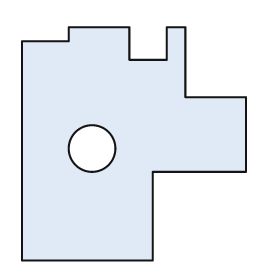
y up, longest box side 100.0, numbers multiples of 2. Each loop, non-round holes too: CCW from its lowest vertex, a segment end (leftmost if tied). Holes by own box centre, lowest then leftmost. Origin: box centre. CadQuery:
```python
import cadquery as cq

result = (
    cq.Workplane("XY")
    .moveTo(-48.0, -50.0)
    .lineTo(8.0, -50.0)
    .lineTo(8.0, -12.0)
    .lineTo(48.0, -12.0)
    .lineTo(48.0, 20.0)
    .lineTo(22.0, 20.0)
    .lineTo(22.0, 50.0)
    .lineTo(14.0, 50.0)
    .lineTo(14.0, 36.0)
    .lineTo(-2.0, 36.0)
    .lineTo(-2.0, 50.0)
    .lineTo(-28.0, 50.0)
    .lineTo(-28.0, 44.0)
    .lineTo(-48.0, 44.0)
    .close()
    .moveTo(-18.0, -2.0)
    .circle(10.0)
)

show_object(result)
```